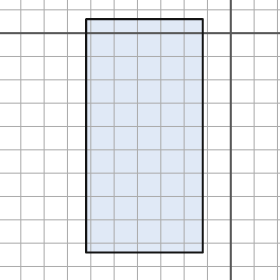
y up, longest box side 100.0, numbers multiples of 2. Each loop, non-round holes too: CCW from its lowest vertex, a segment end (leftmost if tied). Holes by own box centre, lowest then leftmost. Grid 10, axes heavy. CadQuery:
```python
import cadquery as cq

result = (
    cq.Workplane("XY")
    .moveTo(-62.0, -94.0)
    .lineTo(-12.0, -94.0)
    .lineTo(-12.0, 6.0)
    .lineTo(-62.0, 6.0)
    .close()
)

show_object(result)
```